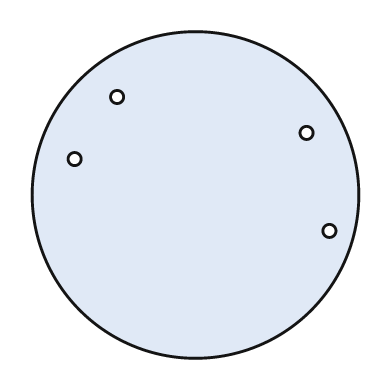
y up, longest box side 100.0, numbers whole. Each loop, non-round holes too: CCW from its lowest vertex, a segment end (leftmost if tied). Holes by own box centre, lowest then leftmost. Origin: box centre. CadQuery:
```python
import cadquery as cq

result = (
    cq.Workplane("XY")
    .moveTo(0.0, 0.0)
    .circle(50.0)
    .moveTo(41.0, -11.0)
    .circle(2.0)
    .moveTo(-37.0, 11.0)
    .circle(2.0)
    .moveTo(34.0, 19.0)
    .circle(2.0)
    .moveTo(-24.0, 30.0)
    .circle(2.0)
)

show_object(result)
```